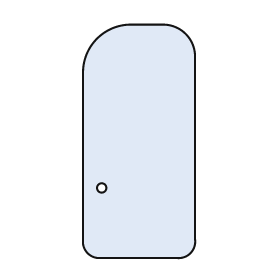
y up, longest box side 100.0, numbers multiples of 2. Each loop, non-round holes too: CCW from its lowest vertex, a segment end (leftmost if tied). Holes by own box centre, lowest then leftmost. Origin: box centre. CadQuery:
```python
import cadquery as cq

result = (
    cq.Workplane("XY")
    .moveTo(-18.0, -50.0)
    .lineTo(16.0, -50.0)
    .threePointArc((22.0, -48.0), (24.0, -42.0))
    .lineTo(24.0, 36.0)
    .threePointArc((20.0, 46.0), (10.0, 50.0))
    .lineTo(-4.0, 50.0)
    .threePointArc((-18.0, 44.0), (-24.0, 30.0))
    .lineTo(-24.0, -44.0)
    .threePointArc((-22.0, -48.0), (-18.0, -50.0))
    .close()
    .moveTo(-16.0, -20.0)
    .circle(2.0)
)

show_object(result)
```